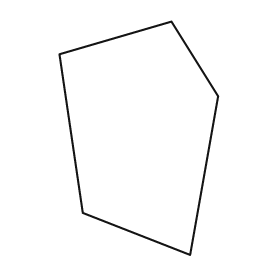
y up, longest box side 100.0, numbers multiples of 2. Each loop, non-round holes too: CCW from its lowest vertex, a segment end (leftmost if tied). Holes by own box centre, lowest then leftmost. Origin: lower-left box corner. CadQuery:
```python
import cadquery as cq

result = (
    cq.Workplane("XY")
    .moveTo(56.0, 0.0)
    .lineTo(68.0, 68.0)
    .lineTo(48.0, 100.0)
    .lineTo(0.0, 86.0)
    .lineTo(10.0, 18.0)
    .close()
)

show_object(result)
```